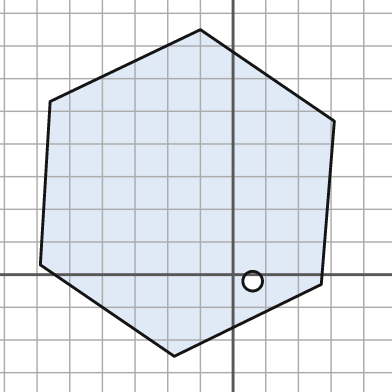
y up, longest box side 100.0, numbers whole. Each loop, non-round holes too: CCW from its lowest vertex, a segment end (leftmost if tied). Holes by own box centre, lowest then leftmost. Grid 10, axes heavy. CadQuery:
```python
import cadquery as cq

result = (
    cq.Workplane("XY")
    .moveTo(-18.0, -25.0)
    .lineTo(27.0, -3.0)
    .lineTo(31.0, 47.0)
    .lineTo(-10.0, 75.0)
    .lineTo(-56.0, 53.0)
    .lineTo(-59.0, 3.0)
    .close()
    .moveTo(6.0, -2.0)
    .circle(3.0)
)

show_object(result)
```